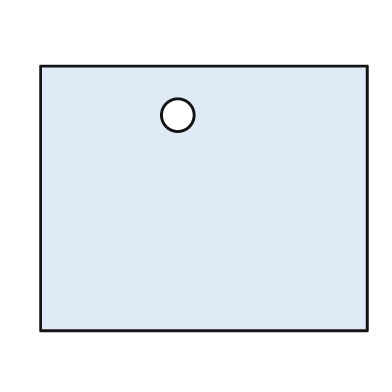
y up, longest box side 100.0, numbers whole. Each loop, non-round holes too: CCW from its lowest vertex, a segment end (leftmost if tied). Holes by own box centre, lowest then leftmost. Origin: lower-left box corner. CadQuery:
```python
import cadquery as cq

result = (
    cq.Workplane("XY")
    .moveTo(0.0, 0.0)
    .lineTo(100.0, 0.0)
    .lineTo(100.0, 81.0)
    .lineTo(0.0, 81.0)
    .close()
    .moveTo(42.0, 66.0)
    .circle(5.0)
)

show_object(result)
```